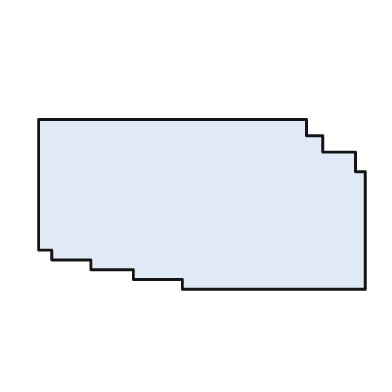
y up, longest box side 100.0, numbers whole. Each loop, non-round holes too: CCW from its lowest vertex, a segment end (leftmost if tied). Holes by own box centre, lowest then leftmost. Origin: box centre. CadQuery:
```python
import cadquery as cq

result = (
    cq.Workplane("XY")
    .moveTo(-6.0, -26.0)
    .lineTo(50.0, -26.0)
    .lineTo(50.0, 10.0)
    .lineTo(47.0, 10.0)
    .lineTo(47.0, 16.0)
    .lineTo(37.0, 16.0)
    .lineTo(37.0, 21.0)
    .lineTo(32.0, 21.0)
    .lineTo(32.0, 26.0)
    .lineTo(-50.0, 26.0)
    .lineTo(-50.0, -14.0)
    .lineTo(-46.0, -14.0)
    .lineTo(-46.0, -17.0)
    .lineTo(-34.0, -17.0)
    .lineTo(-34.0, -20.0)
    .lineTo(-21.0, -20.0)
    .lineTo(-21.0, -23.0)
    .lineTo(-6.0, -23.0)
    .close()
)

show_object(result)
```